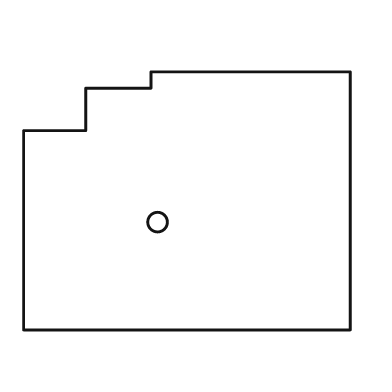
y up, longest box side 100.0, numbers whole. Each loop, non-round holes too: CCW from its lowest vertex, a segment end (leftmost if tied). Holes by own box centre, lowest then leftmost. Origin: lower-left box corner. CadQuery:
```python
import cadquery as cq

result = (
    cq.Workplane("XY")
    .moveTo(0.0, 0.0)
    .lineTo(100.0, 0.0)
    .lineTo(100.0, 79.0)
    .lineTo(39.0, 79.0)
    .lineTo(39.0, 74.0)
    .lineTo(19.0, 74.0)
    .lineTo(19.0, 61.0)
    .lineTo(0.0, 61.0)
    .close()
    .moveTo(41.0, 33.0)
    .circle(3.0)
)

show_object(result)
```